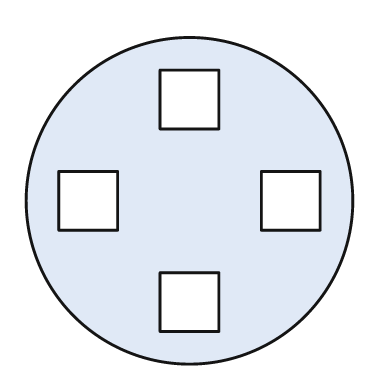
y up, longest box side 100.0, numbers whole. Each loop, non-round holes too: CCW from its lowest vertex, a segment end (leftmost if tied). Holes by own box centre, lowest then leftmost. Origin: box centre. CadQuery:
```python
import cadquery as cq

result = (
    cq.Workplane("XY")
    .moveTo(0.0, 0.0)
    .circle(50.0)
    .moveTo(-9.0, -40.0)
    .lineTo(9.0, -40.0)
    .lineTo(9.0, -22.0)
    .lineTo(-9.0, -22.0)
    .close()
    .moveTo(-40.0, -9.0)
    .lineTo(-22.0, -9.0)
    .lineTo(-22.0, 9.0)
    .lineTo(-40.0, 9.0)
    .close()
    .moveTo(22.0, -9.0)
    .lineTo(40.0, -9.0)
    .lineTo(40.0, 9.0)
    .lineTo(22.0, 9.0)
    .close()
    .moveTo(-9.0, 22.0)
    .lineTo(9.0, 22.0)
    .lineTo(9.0, 40.0)
    .lineTo(-9.0, 40.0)
    .close()
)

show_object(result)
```